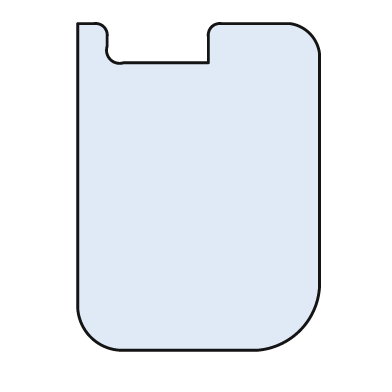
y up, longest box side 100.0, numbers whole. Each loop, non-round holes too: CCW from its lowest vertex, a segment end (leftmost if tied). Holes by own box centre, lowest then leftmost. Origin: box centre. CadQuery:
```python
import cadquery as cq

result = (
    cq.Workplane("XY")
    .moveTo(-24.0, -50.0)
    .lineTo(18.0, -50.0)
    .threePointArc((31.0, -44.0), (37.0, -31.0))
    .lineTo(37.0, 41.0)
    .threePointArc((34.0, 47.0), (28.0, 50.0))
    .lineTo(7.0, 50.0)
    .threePointArc((4.0, 49.0), (3.0, 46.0))
    .lineTo(3.0, 38.0)
    .lineTo(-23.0, 38.0)
    .threePointArc((-27.0, 39.0), (-28.0, 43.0))
    .lineTo(-28.0, 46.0)
    .threePointArc((-29.0, 49.0), (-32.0, 50.0))
    .lineTo(-37.0, 50.0)
    .lineTo(-37.0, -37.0)
    .threePointArc((-33.0, -46.0), (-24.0, -50.0))
    .close()
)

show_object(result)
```